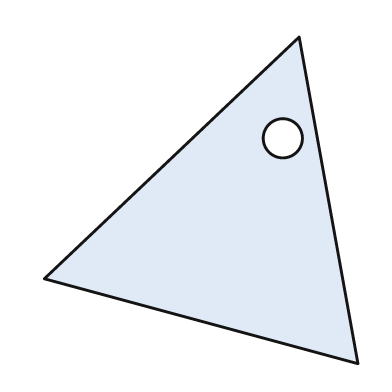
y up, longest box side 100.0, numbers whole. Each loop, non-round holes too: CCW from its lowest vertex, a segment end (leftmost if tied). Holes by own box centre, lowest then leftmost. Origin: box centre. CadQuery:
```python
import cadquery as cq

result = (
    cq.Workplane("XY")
    .moveTo(48.0, -50.0)
    .lineTo(30.0, 50.0)
    .lineTo(-48.0, -24.0)
    .close()
    .moveTo(25.0, 19.0)
    .circle(6.0)
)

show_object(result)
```